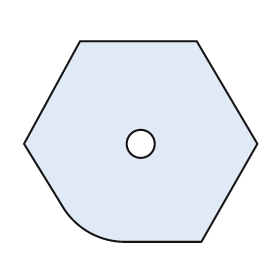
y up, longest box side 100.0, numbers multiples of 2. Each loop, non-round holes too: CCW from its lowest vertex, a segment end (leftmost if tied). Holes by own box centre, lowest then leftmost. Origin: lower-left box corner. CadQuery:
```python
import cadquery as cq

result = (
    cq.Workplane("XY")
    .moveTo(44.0, 0.0)
    .lineTo(76.0, 0.0)
    .lineTo(100.0, 42.0)
    .lineTo(74.0, 86.0)
    .lineTo(24.0, 86.0)
    .lineTo(0.0, 42.0)
    .lineTo(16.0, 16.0)
    .threePointArc((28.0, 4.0), (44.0, 0.0))
    .close()
    .moveTo(50.0, 42.0)
    .circle(6.0)
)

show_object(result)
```